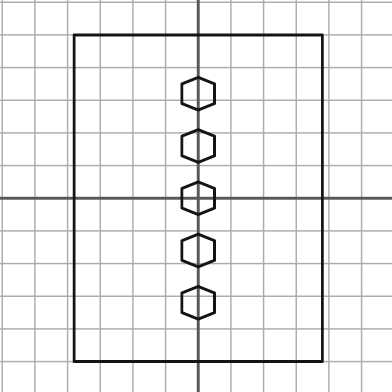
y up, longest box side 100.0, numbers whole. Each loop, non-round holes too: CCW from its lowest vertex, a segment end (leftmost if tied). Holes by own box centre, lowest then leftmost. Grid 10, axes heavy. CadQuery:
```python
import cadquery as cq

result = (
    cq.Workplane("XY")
    .moveTo(-38.0, -50.0)
    .lineTo(38.0, -50.0)
    .lineTo(38.0, 50.0)
    .lineTo(-38.0, 50.0)
    .close()
    .moveTo(0.0, -37.0)
    .lineTo(5.0, -35.0)
    .lineTo(5.0, -29.0)
    .lineTo(0.0, -27.0)
    .lineTo(-5.0, -29.0)
    .lineTo(-5.0, -35.0)
    .close()
    .moveTo(0.0, -21.0)
    .lineTo(5.0, -19.0)
    .lineTo(5.0, -13.0)
    .lineTo(0.0, -11.0)
    .lineTo(-5.0, -13.0)
    .lineTo(-5.0, -19.0)
    .close()
    .moveTo(0.0, -5.0)
    .lineTo(5.0, -3.0)
    .lineTo(5.0, 3.0)
    .lineTo(0.0, 5.0)
    .lineTo(-5.0, 3.0)
    .lineTo(-5.0, -3.0)
    .close()
    .moveTo(0.0, 11.0)
    .lineTo(5.0, 13.0)
    .lineTo(5.0, 19.0)
    .lineTo(0.0, 21.0)
    .lineTo(-5.0, 19.0)
    .lineTo(-5.0, 13.0)
    .close()
    .moveTo(0.0, 27.0)
    .lineTo(5.0, 29.0)
    .lineTo(5.0, 35.0)
    .lineTo(0.0, 37.0)
    .lineTo(-5.0, 35.0)
    .lineTo(-5.0, 29.0)
    .close()
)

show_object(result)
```